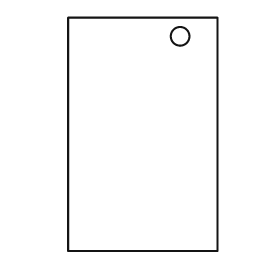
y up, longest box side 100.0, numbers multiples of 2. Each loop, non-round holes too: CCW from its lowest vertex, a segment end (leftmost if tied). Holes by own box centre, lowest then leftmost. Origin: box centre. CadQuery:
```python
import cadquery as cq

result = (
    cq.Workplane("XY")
    .moveTo(-32.0, -50.0)
    .lineTo(32.0, -50.0)
    .lineTo(32.0, 50.0)
    .lineTo(-32.0, 50.0)
    .close()
    .moveTo(16.0, 42.0)
    .circle(4.0)
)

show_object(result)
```